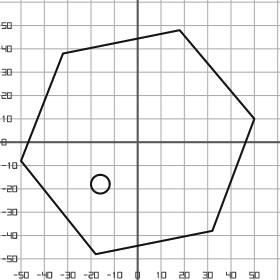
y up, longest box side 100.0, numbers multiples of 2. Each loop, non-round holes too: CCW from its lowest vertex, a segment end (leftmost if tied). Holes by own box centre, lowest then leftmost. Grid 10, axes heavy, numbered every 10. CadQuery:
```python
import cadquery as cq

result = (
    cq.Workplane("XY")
    .moveTo(-18.0, -48.0)
    .lineTo(32.0, -38.0)
    .lineTo(50.0, 10.0)
    .lineTo(18.0, 48.0)
    .lineTo(-32.0, 38.0)
    .lineTo(-50.0, -8.0)
    .close()
    .moveTo(-16.0, -18.0)
    .circle(4.0)
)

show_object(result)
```